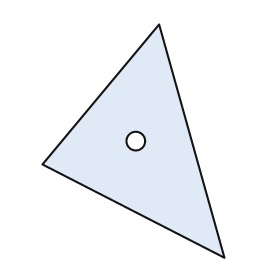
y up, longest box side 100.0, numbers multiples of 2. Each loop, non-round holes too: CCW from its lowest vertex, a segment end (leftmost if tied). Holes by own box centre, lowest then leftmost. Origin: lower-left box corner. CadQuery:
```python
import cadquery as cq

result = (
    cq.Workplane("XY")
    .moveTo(78.0, 0.0)
    .lineTo(50.0, 100.0)
    .lineTo(0.0, 40.0)
    .close()
    .moveTo(40.0, 50.0)
    .circle(4.0)
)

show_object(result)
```